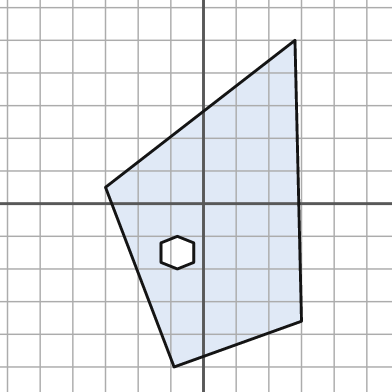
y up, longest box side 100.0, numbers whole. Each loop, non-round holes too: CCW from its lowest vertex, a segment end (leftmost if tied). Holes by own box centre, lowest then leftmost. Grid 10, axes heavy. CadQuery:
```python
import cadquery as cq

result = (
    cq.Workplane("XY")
    .moveTo(-9.0, -50.0)
    .lineTo(30.0, -36.0)
    .lineTo(28.0, 50.0)
    .lineTo(-30.0, 5.0)
    .close()
    .moveTo(-8.0, -20.0)
    .lineTo(-3.0, -18.0)
    .lineTo(-3.0, -12.0)
    .lineTo(-8.0, -10.0)
    .lineTo(-13.0, -12.0)
    .lineTo(-13.0, -18.0)
    .close()
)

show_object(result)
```